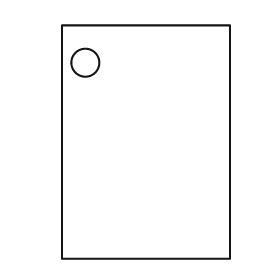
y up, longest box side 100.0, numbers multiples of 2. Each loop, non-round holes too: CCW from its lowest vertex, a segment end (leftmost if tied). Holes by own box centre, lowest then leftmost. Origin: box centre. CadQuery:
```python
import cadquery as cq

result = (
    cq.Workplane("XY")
    .moveTo(-36.0, -50.0)
    .lineTo(36.0, -50.0)
    .lineTo(36.0, 50.0)
    .lineTo(-36.0, 50.0)
    .close()
    .moveTo(-26.0, 34.0)
    .circle(6.0)
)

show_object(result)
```